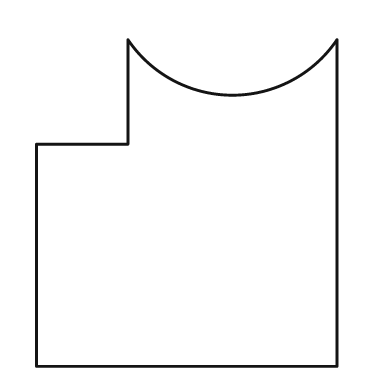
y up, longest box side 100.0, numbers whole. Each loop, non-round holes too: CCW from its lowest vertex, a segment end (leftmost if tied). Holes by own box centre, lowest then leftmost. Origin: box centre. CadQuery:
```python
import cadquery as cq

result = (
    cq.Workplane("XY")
    .moveTo(-46.0, -50.0)
    .lineTo(46.0, -50.0)
    .lineTo(46.0, 50.0)
    .threePointArc((14.0, 33.0), (-18.0, 50.0))
    .lineTo(-18.0, 18.0)
    .lineTo(-46.0, 18.0)
    .close()
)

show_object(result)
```